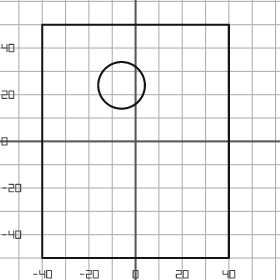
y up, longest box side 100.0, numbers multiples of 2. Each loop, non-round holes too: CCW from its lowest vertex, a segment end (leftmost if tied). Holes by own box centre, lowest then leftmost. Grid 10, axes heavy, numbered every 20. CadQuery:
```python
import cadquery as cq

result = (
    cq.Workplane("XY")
    .moveTo(-40.0, -50.0)
    .lineTo(40.0, -50.0)
    .lineTo(40.0, 50.0)
    .lineTo(-40.0, 50.0)
    .close()
    .moveTo(-6.0, 24.0)
    .circle(10.0)
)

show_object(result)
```